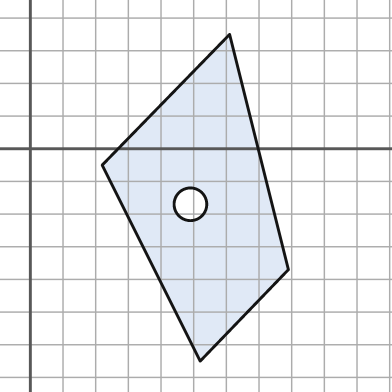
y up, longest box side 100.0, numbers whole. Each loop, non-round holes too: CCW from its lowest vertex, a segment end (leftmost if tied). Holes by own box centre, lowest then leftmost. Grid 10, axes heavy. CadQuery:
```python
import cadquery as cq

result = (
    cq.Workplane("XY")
    .moveTo(52.0, -65.0)
    .lineTo(79.0, -37.0)
    .lineTo(61.0, 35.0)
    .lineTo(22.0, -5.0)
    .close()
    .moveTo(49.0, -17.0)
    .circle(5.0)
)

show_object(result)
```